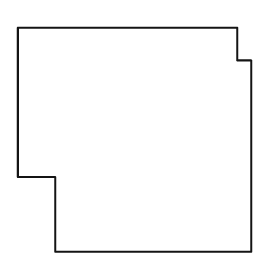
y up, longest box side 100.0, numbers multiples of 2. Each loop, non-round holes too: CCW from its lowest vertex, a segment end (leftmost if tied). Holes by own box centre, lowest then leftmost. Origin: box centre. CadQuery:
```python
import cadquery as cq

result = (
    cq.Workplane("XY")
    .moveTo(-34.0, -48.0)
    .lineTo(50.0, -48.0)
    .lineTo(50.0, 34.0)
    .lineTo(44.0, 34.0)
    .lineTo(44.0, 48.0)
    .lineTo(-50.0, 48.0)
    .lineTo(-50.0, -16.0)
    .lineTo(-34.0, -16.0)
    .close()
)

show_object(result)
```